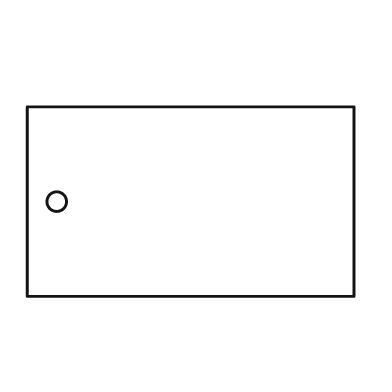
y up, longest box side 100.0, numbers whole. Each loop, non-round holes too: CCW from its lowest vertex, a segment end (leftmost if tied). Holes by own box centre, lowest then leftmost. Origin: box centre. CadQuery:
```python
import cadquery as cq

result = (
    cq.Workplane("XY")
    .moveTo(-50.0, -29.0)
    .lineTo(50.0, -29.0)
    .lineTo(50.0, 29.0)
    .lineTo(-50.0, 29.0)
    .close()
    .moveTo(-41.0, 0.0)
    .circle(3.0)
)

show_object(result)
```